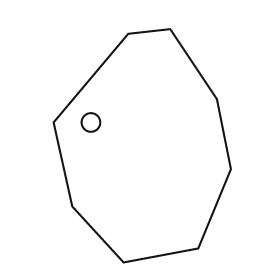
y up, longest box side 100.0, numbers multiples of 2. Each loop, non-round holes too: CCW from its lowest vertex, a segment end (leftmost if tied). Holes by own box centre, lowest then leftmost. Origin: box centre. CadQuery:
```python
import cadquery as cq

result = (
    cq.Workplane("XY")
    .moveTo(-8.0, -50.0)
    .lineTo(24.0, -44.0)
    .lineTo(38.0, -10.0)
    .lineTo(32.0, 20.0)
    .lineTo(12.0, 50.0)
    .lineTo(-6.0, 48.0)
    .lineTo(-38.0, 10.0)
    .lineTo(-30.0, -26.0)
    .close()
    .moveTo(-22.0, 10.0)
    .circle(4.0)
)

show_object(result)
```